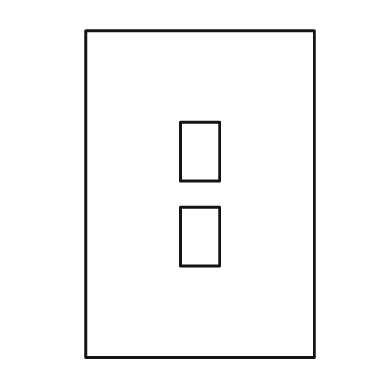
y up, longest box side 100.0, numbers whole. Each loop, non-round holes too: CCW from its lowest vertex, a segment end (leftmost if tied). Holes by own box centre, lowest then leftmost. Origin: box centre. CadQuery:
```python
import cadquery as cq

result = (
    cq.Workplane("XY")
    .moveTo(-35.0, -50.0)
    .lineTo(35.0, -50.0)
    .lineTo(35.0, 50.0)
    .lineTo(-35.0, 50.0)
    .close()
    .moveTo(-6.0, -22.0)
    .lineTo(6.0, -22.0)
    .lineTo(6.0, -4.0)
    .lineTo(-6.0, -4.0)
    .close()
    .moveTo(-6.0, 4.0)
    .lineTo(6.0, 4.0)
    .lineTo(6.0, 22.0)
    .lineTo(-6.0, 22.0)
    .close()
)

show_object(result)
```